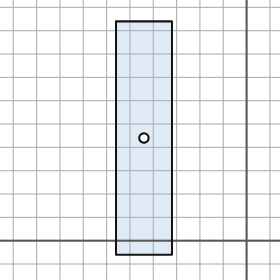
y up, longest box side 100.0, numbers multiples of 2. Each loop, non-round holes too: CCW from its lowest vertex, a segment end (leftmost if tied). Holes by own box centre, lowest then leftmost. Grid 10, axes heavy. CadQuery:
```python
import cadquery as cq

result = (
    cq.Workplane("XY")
    .moveTo(-56.0, -6.0)
    .lineTo(-32.0, -6.0)
    .lineTo(-32.0, 94.0)
    .lineTo(-56.0, 94.0)
    .close()
    .moveTo(-44.0, 44.0)
    .circle(2.0)
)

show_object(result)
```